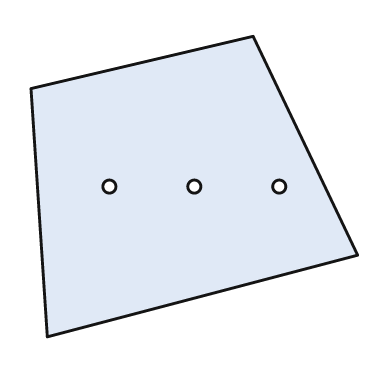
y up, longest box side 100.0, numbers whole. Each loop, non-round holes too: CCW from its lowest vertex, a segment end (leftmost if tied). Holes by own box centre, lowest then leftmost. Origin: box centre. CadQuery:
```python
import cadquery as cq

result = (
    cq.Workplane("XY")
    .moveTo(-45.0, -46.0)
    .lineTo(50.0, -21.0)
    .lineTo(18.0, 46.0)
    .lineTo(-50.0, 30.0)
    .close()
    .moveTo(-26.0, 0.0)
    .circle(2.0)
    .moveTo(0.0, 0.0)
    .circle(2.0)
    .moveTo(26.0, 0.0)
    .circle(2.0)
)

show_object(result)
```